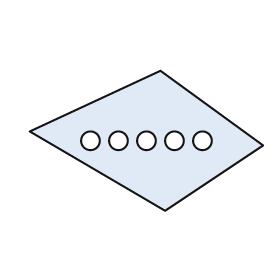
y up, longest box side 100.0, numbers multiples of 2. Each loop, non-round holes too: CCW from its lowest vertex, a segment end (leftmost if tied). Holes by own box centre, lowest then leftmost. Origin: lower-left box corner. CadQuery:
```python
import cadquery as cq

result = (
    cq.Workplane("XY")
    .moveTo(58.0, 0.0)
    .lineTo(100.0, 28.0)
    .lineTo(56.0, 60.0)
    .lineTo(0.0, 34.0)
    .close()
    .moveTo(26.0, 30.0)
    .circle(4.0)
    .moveTo(38.0, 30.0)
    .circle(4.0)
    .moveTo(50.0, 30.0)
    .circle(4.0)
    .moveTo(62.0, 30.0)
    .circle(4.0)
    .moveTo(74.0, 30.0)
    .circle(4.0)
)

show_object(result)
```